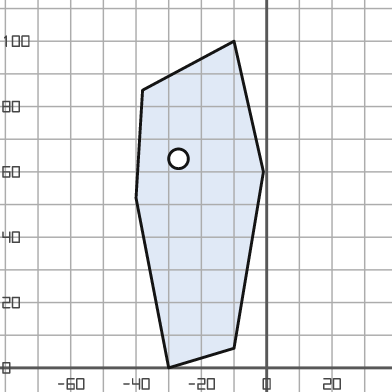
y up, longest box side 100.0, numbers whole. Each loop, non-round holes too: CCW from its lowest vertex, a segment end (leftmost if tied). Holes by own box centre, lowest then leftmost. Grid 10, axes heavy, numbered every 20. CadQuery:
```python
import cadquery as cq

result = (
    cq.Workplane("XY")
    .moveTo(-30.0, 0.0)
    .lineTo(-10.0, 6.0)
    .lineTo(-1.0, 60.0)
    .lineTo(-10.0, 100.0)
    .lineTo(-38.0, 85.0)
    .lineTo(-40.0, 52.0)
    .close()
    .moveTo(-27.0, 64.0)
    .circle(3.0)
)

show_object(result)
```